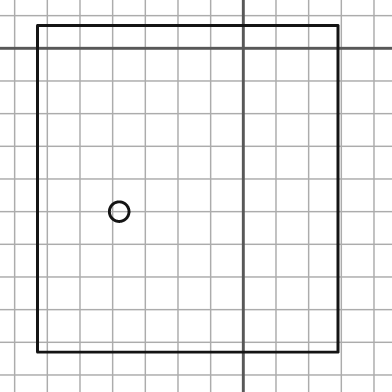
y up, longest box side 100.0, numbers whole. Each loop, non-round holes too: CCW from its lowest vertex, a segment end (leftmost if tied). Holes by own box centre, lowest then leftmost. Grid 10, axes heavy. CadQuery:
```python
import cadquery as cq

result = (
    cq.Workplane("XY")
    .moveTo(-63.0, -93.0)
    .lineTo(29.0, -93.0)
    .lineTo(29.0, 7.0)
    .lineTo(-63.0, 7.0)
    .close()
    .moveTo(-38.0, -50.0)
    .circle(3.0)
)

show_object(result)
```